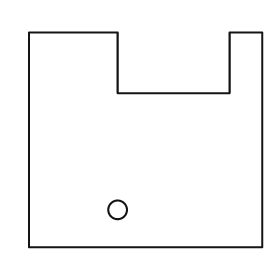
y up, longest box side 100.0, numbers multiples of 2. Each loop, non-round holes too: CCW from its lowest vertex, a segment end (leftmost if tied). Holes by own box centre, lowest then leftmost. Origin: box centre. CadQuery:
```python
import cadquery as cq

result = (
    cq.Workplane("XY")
    .moveTo(-50.0, -46.0)
    .lineTo(50.0, -46.0)
    .lineTo(50.0, 46.0)
    .lineTo(36.0, 46.0)
    .lineTo(36.0, 20.0)
    .lineTo(-12.0, 20.0)
    .lineTo(-12.0, 46.0)
    .lineTo(-50.0, 46.0)
    .close()
    .moveTo(-12.0, -30.0)
    .circle(4.0)
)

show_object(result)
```